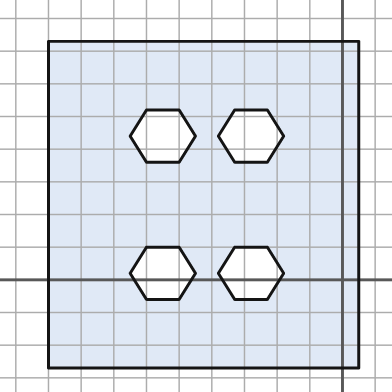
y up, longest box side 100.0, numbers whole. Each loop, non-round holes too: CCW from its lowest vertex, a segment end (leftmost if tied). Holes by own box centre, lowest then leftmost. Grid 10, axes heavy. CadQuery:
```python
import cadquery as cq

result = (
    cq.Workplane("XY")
    .moveTo(-90.0, -27.0)
    .lineTo(5.0, -27.0)
    .lineTo(5.0, 73.0)
    .lineTo(-90.0, 73.0)
    .close()
    .moveTo(-60.0, -6.0)
    .lineTo(-50.0, -6.0)
    .lineTo(-45.0, 2.0)
    .lineTo(-50.0, 10.0)
    .lineTo(-60.0, 10.0)
    .lineTo(-65.0, 2.0)
    .close()
    .moveTo(-33.0, -6.0)
    .lineTo(-23.0, -6.0)
    .lineTo(-18.0, 2.0)
    .lineTo(-23.0, 10.0)
    .lineTo(-33.0, 10.0)
    .lineTo(-38.0, 2.0)
    .close()
    .moveTo(-60.0, 36.0)
    .lineTo(-50.0, 36.0)
    .lineTo(-45.0, 44.0)
    .lineTo(-50.0, 52.0)
    .lineTo(-60.0, 52.0)
    .lineTo(-65.0, 44.0)
    .close()
    .moveTo(-33.0, 36.0)
    .lineTo(-23.0, 36.0)
    .lineTo(-18.0, 44.0)
    .lineTo(-23.0, 52.0)
    .lineTo(-33.0, 52.0)
    .lineTo(-38.0, 44.0)
    .close()
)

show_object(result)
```